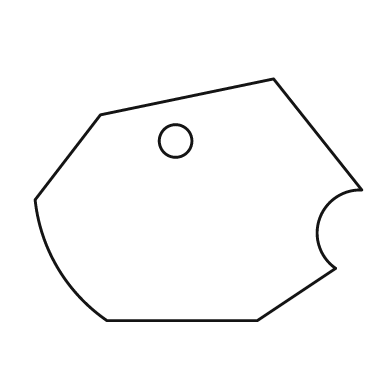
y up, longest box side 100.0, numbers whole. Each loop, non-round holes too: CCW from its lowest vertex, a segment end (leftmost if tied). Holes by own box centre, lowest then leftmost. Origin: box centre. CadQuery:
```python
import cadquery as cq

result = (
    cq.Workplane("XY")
    .moveTo(-28.0, -37.0)
    .lineTo(18.0, -37.0)
    .lineTo(42.0, -21.0)
    .threePointArc((37.0, -6.0), (50.0, 3.0))
    .lineTo(23.0, 37.0)
    .lineTo(-30.0, 26.0)
    .lineTo(-50.0, 0.0)
    .threePointArc((-43.0, -21.0), (-28.0, -37.0))
    .close()
    .moveTo(-7.0, 18.0)
    .circle(5.0)
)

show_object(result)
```